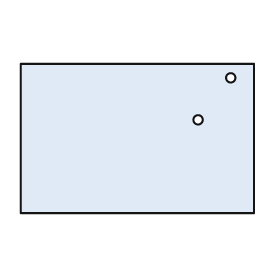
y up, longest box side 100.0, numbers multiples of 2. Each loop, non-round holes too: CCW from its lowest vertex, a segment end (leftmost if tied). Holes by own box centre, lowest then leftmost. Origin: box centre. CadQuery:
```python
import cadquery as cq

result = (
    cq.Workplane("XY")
    .moveTo(-50.0, -32.0)
    .lineTo(50.0, -32.0)
    .lineTo(50.0, 32.0)
    .lineTo(-50.0, 32.0)
    .close()
    .moveTo(26.0, 8.0)
    .circle(2.0)
    .moveTo(40.0, 26.0)
    .circle(2.0)
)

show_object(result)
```